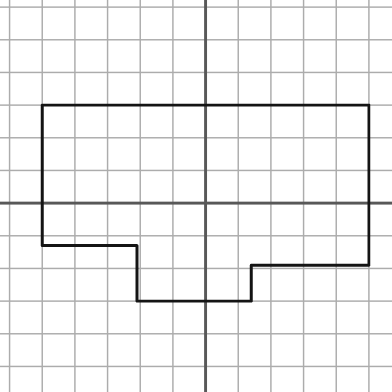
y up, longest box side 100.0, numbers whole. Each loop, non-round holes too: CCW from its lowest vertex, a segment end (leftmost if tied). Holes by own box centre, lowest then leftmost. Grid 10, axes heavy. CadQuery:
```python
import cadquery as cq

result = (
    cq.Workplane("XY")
    .moveTo(-21.0, -30.0)
    .lineTo(14.0, -30.0)
    .lineTo(14.0, -19.0)
    .lineTo(50.0, -19.0)
    .lineTo(50.0, 30.0)
    .lineTo(-50.0, 30.0)
    .lineTo(-50.0, -13.0)
    .lineTo(-21.0, -13.0)
    .close()
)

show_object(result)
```